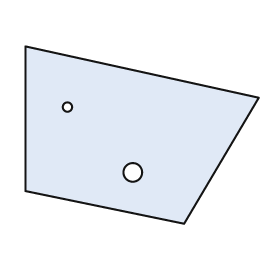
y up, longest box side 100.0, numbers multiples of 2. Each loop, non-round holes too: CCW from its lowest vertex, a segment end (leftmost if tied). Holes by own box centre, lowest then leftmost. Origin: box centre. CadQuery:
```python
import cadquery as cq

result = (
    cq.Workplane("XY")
    .moveTo(18.0, -38.0)
    .lineTo(50.0, 16.0)
    .lineTo(-50.0, 38.0)
    .lineTo(-50.0, -24.0)
    .close()
    .moveTo(-4.0, -16.0)
    .circle(4.0)
    .moveTo(-32.0, 12.0)
    .circle(2.0)
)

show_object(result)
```